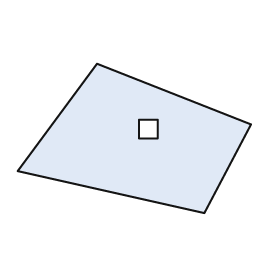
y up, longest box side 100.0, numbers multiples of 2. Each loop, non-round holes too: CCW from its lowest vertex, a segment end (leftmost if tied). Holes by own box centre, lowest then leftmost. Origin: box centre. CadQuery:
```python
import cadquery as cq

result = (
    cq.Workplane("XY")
    .moveTo(30.0, -32.0)
    .lineTo(50.0, 6.0)
    .lineTo(-16.0, 32.0)
    .lineTo(-50.0, -14.0)
    .close()
    .moveTo(2.0, 0.0)
    .lineTo(10.0, 0.0)
    .lineTo(10.0, 8.0)
    .lineTo(2.0, 8.0)
    .close()
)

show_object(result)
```